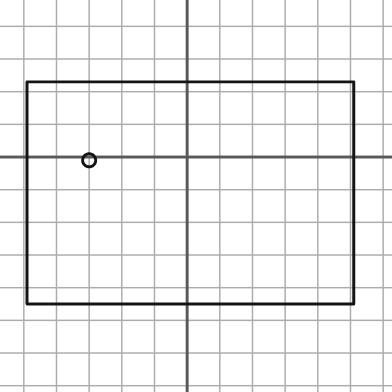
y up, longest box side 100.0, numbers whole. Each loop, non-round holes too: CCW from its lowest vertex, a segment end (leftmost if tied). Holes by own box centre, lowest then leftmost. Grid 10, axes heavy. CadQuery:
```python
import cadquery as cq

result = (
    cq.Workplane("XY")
    .moveTo(-49.0, -45.0)
    .lineTo(51.0, -45.0)
    .lineTo(51.0, 23.0)
    .lineTo(-49.0, 23.0)
    .close()
    .moveTo(-30.0, -1.0)
    .circle(2.0)
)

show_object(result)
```